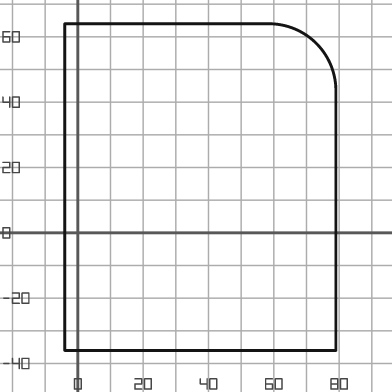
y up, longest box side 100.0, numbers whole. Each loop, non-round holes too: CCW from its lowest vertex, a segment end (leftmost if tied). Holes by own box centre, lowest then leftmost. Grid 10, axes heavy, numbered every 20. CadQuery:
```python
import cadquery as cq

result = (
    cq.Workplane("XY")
    .moveTo(-4.0, -36.0)
    .lineTo(79.0, -36.0)
    .lineTo(79.0, 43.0)
    .threePointArc((73.0, 58.0), (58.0, 64.0))
    .lineTo(-4.0, 64.0)
    .close()
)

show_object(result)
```